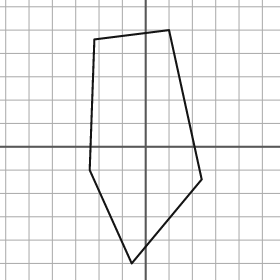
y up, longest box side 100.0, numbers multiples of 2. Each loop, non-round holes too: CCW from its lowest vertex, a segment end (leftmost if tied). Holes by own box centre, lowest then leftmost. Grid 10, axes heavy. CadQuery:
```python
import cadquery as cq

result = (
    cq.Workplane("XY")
    .moveTo(-6.0, -50.0)
    .lineTo(24.0, -14.0)
    .lineTo(10.0, 50.0)
    .lineTo(-22.0, 46.0)
    .lineTo(-24.0, -10.0)
    .close()
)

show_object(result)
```